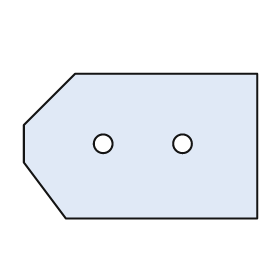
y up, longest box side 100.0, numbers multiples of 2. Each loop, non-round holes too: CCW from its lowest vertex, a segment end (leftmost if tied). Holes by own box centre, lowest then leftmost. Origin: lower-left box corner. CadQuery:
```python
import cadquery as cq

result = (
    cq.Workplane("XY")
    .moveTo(18.0, 0.0)
    .lineTo(100.0, 0.0)
    .lineTo(100.0, 62.0)
    .lineTo(22.0, 62.0)
    .lineTo(0.0, 40.0)
    .lineTo(0.0, 24.0)
    .close()
    .moveTo(34.0, 32.0)
    .circle(4.0)
    .moveTo(68.0, 32.0)
    .circle(4.0)
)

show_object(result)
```